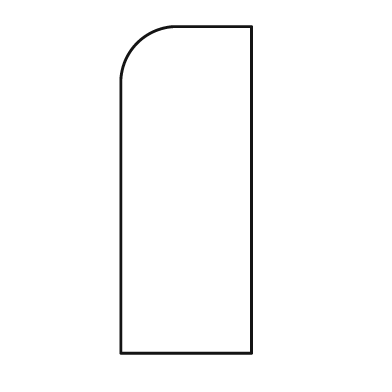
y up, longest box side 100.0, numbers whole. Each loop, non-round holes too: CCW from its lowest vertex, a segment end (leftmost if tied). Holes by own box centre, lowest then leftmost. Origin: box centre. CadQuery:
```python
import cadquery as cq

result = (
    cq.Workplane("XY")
    .moveTo(-20.0, -50.0)
    .lineTo(20.0, -50.0)
    .lineTo(20.0, 50.0)
    .lineTo(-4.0, 50.0)
    .threePointArc((-15.0, 45.0), (-20.0, 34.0))
    .close()
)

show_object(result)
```